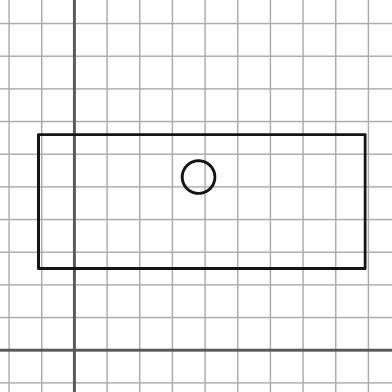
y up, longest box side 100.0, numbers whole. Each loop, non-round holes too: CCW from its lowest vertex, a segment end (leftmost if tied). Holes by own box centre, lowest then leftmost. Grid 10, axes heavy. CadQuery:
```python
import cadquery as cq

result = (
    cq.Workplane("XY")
    .moveTo(-11.0, 25.0)
    .lineTo(89.0, 25.0)
    .lineTo(89.0, 66.0)
    .lineTo(-11.0, 66.0)
    .close()
    .moveTo(38.0, 53.0)
    .circle(5.0)
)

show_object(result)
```